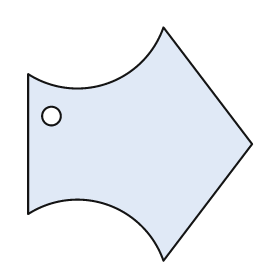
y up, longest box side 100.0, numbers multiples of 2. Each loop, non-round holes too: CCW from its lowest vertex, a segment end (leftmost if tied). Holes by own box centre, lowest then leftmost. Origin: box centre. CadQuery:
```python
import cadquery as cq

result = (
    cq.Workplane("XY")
    .moveTo(10.0, -50.0)
    .lineTo(48.0, 0.0)
    .lineTo(10.0, 50.0)
    .threePointArc((-14.0, 26.0), (-48.0, 30.0))
    .lineTo(-48.0, -30.0)
    .threePointArc((-14.0, -26.0), (10.0, -50.0))
    .close()
    .moveTo(-38.0, 12.0)
    .circle(4.0)
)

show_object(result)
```